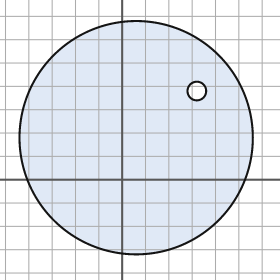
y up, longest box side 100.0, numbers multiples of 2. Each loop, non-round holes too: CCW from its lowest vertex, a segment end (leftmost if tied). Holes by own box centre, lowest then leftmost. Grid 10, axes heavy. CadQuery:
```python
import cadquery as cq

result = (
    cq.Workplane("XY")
    .moveTo(6.0, 18.0)
    .circle(50.0)
    .moveTo(32.0, 38.0)
    .circle(4.0)
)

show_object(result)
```